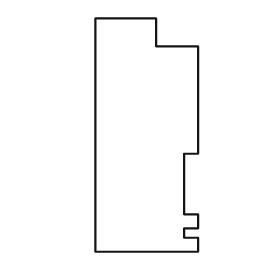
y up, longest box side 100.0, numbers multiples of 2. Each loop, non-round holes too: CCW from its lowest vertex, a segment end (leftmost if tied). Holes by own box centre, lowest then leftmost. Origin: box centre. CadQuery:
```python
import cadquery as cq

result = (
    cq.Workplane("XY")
    .moveTo(-22.0, -50.0)
    .lineTo(22.0, -50.0)
    .lineTo(22.0, -44.0)
    .lineTo(16.0, -44.0)
    .lineTo(16.0, -40.0)
    .lineTo(22.0, -40.0)
    .lineTo(22.0, -34.0)
    .lineTo(16.0, -34.0)
    .lineTo(16.0, -8.0)
    .lineTo(22.0, -8.0)
    .lineTo(22.0, 38.0)
    .lineTo(4.0, 38.0)
    .lineTo(4.0, 50.0)
    .lineTo(-22.0, 50.0)
    .close()
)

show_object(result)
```